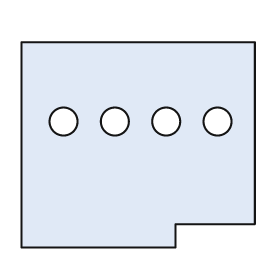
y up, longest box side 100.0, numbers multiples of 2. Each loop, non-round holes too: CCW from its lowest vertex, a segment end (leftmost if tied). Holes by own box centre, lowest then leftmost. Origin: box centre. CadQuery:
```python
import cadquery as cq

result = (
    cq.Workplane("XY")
    .moveTo(-50.0, -44.0)
    .lineTo(16.0, -44.0)
    .lineTo(16.0, -34.0)
    .lineTo(50.0, -34.0)
    .lineTo(50.0, 44.0)
    .lineTo(-50.0, 44.0)
    .close()
    .moveTo(-32.0, 10.0)
    .circle(6.0)
    .moveTo(-10.0, 10.0)
    .circle(6.0)
    .moveTo(12.0, 10.0)
    .circle(6.0)
    .moveTo(34.0, 10.0)
    .circle(6.0)
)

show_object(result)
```